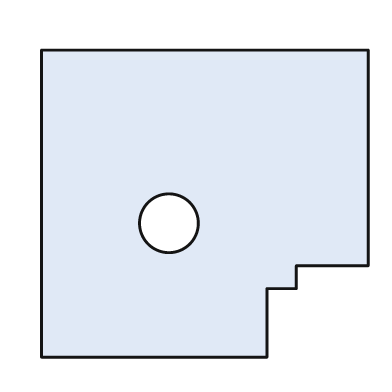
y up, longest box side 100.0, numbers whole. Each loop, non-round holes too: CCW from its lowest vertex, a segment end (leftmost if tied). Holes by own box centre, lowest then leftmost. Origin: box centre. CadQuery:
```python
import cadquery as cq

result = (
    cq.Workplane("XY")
    .moveTo(-50.0, -47.0)
    .lineTo(19.0, -47.0)
    .lineTo(19.0, -26.0)
    .lineTo(28.0, -26.0)
    .lineTo(28.0, -19.0)
    .lineTo(50.0, -19.0)
    .lineTo(50.0, 47.0)
    .lineTo(-50.0, 47.0)
    .close()
    .moveTo(-11.0, -6.0)
    .circle(9.0)
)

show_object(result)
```